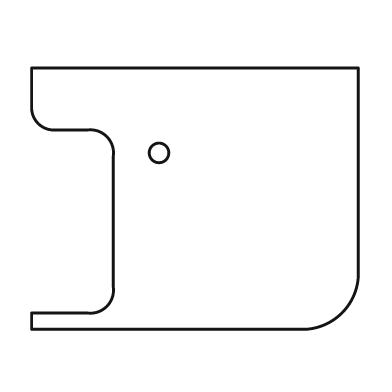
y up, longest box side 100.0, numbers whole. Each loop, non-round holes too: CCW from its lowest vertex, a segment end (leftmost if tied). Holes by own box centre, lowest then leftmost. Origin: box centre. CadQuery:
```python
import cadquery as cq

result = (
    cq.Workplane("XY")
    .moveTo(-50.0, -40.0)
    .lineTo(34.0, -40.0)
    .threePointArc((45.0, -35.0), (50.0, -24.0))
    .lineTo(50.0, 40.0)
    .lineTo(-50.0, 40.0)
    .lineTo(-50.0, 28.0)
    .threePointArc((-48.0, 23.0), (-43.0, 21.0))
    .lineTo(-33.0, 21.0)
    .threePointArc((-27.0, 19.0), (-25.0, 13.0))
    .lineTo(-25.0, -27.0)
    .threePointArc((-27.0, -33.0), (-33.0, -35.0))
    .lineTo(-50.0, -35.0)
    .close()
    .moveTo(-11.0, 14.0)
    .circle(3.0)
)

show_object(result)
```